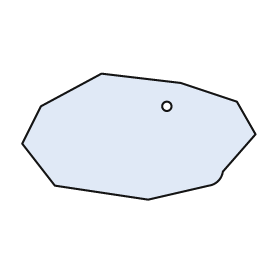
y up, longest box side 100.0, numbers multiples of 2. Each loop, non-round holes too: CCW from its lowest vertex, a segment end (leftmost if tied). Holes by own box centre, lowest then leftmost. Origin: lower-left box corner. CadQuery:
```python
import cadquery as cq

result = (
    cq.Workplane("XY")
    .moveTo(54.0, 0.0)
    .lineTo(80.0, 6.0)
    .threePointArc((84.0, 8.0), (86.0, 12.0))
    .lineTo(100.0, 28.0)
    .lineTo(92.0, 42.0)
    .lineTo(68.0, 50.0)
    .lineTo(34.0, 54.0)
    .lineTo(8.0, 40.0)
    .lineTo(0.0, 24.0)
    .lineTo(14.0, 6.0)
    .close()
    .moveTo(62.0, 40.0)
    .circle(2.0)
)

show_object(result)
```